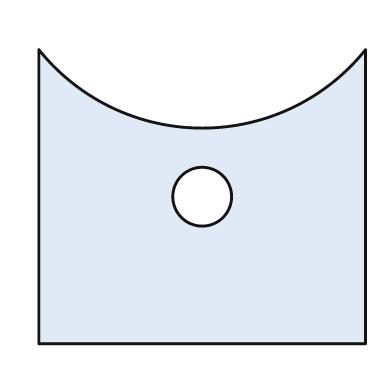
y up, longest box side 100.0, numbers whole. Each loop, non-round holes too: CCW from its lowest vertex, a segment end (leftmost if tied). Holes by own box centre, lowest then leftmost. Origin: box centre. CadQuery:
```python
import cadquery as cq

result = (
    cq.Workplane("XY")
    .moveTo(-50.0, -45.0)
    .lineTo(50.0, -45.0)
    .lineTo(50.0, 45.0)
    .threePointArc((0.0, 21.0), (-50.0, 45.0))
    .close()
    .moveTo(0.0, 0.0)
    .circle(9.0)
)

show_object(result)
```